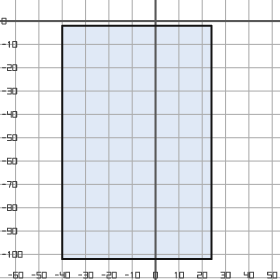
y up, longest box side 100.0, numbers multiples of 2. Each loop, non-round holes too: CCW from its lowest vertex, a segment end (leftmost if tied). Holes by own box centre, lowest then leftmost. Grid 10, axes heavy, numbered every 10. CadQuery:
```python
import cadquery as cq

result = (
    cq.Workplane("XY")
    .moveTo(-40.0, -102.0)
    .lineTo(24.0, -102.0)
    .lineTo(24.0, -2.0)
    .lineTo(-40.0, -2.0)
    .close()
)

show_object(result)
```